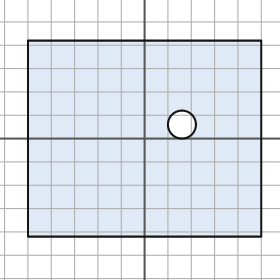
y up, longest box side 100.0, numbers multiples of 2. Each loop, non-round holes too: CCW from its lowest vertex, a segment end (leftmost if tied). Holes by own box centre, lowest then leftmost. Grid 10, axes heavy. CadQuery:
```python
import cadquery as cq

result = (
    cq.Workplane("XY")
    .moveTo(-50.0, -42.0)
    .lineTo(50.0, -42.0)
    .lineTo(50.0, 42.0)
    .lineTo(-50.0, 42.0)
    .close()
    .moveTo(16.0, 6.0)
    .circle(6.0)
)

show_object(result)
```